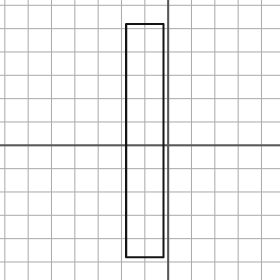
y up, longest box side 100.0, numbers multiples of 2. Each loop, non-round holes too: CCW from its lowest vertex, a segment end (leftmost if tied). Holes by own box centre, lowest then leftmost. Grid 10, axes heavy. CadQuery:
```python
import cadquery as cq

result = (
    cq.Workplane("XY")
    .moveTo(-18.0, -48.0)
    .lineTo(-2.0, -48.0)
    .lineTo(-2.0, 52.0)
    .lineTo(-18.0, 52.0)
    .close()
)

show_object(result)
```